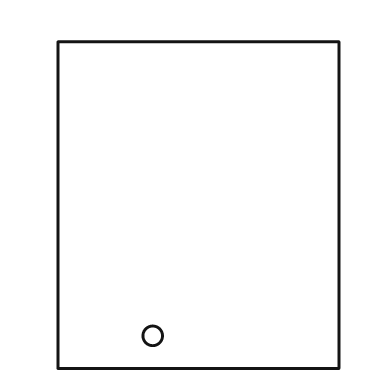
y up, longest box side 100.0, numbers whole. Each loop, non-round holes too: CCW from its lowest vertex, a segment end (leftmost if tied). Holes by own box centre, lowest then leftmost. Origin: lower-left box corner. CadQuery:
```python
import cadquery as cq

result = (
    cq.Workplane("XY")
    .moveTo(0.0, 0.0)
    .lineTo(86.0, 0.0)
    .lineTo(86.0, 100.0)
    .lineTo(0.0, 100.0)
    .close()
    .moveTo(29.0, 10.0)
    .circle(3.0)
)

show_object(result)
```